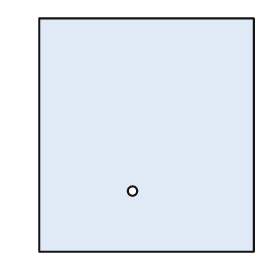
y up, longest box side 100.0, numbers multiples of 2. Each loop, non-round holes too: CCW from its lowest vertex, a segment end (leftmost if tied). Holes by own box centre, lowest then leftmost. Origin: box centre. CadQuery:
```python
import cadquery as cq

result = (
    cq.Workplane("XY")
    .moveTo(-46.0, -50.0)
    .lineTo(46.0, -50.0)
    .lineTo(46.0, 50.0)
    .lineTo(-46.0, 50.0)
    .close()
    .moveTo(-6.0, -24.0)
    .circle(2.0)
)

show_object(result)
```